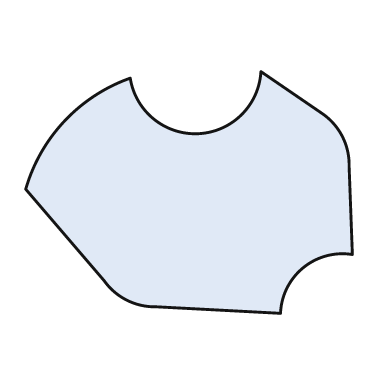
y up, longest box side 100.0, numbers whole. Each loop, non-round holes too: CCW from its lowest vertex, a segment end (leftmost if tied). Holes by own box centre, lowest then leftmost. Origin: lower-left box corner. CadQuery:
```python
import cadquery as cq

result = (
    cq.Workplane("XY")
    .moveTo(78.0, 0.0)
    .threePointArc((85.0, 14.0), (100.0, 18.0))
    .lineTo(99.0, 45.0)
    .threePointArc((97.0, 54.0), (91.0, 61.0))
    .lineTo(72.0, 74.0)
    .threePointArc((53.0, 55.0), (32.0, 72.0))
    .threePointArc((12.0, 59.0), (0.0, 38.0))
    .lineTo(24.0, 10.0)
    .threePointArc((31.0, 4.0), (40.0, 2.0))
    .close()
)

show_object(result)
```